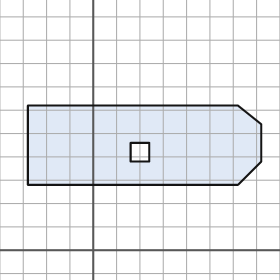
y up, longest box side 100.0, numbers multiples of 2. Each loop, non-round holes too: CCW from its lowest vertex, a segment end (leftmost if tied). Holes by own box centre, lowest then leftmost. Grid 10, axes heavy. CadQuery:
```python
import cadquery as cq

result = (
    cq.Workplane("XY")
    .moveTo(-28.0, 28.0)
    .lineTo(62.0, 28.0)
    .lineTo(72.0, 38.0)
    .lineTo(72.0, 54.0)
    .lineTo(62.0, 62.0)
    .lineTo(-28.0, 62.0)
    .close()
    .moveTo(16.0, 38.0)
    .lineTo(24.0, 38.0)
    .lineTo(24.0, 46.0)
    .lineTo(16.0, 46.0)
    .close()
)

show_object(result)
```